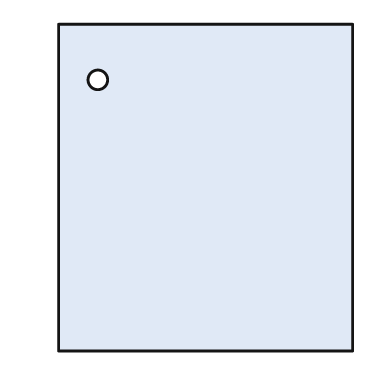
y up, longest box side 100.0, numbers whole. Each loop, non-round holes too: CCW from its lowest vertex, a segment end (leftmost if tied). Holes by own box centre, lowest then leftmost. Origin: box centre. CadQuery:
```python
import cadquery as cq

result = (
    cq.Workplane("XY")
    .moveTo(-45.0, -50.0)
    .lineTo(45.0, -50.0)
    .lineTo(45.0, 50.0)
    .lineTo(-45.0, 50.0)
    .close()
    .moveTo(-33.0, 33.0)
    .circle(3.0)
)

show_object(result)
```